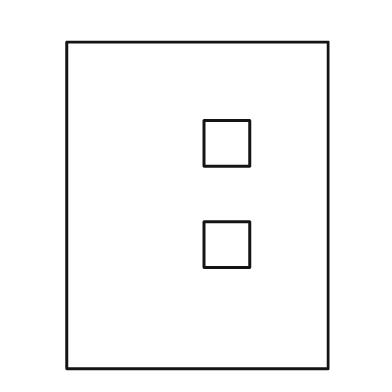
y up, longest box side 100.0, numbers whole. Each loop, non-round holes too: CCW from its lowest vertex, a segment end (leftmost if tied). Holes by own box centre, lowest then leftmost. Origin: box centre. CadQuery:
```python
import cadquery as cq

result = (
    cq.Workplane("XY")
    .moveTo(-40.0, -50.0)
    .lineTo(40.0, -50.0)
    .lineTo(40.0, 50.0)
    .lineTo(-40.0, 50.0)
    .close()
    .moveTo(2.0, -19.0)
    .lineTo(16.0, -19.0)
    .lineTo(16.0, -5.0)
    .lineTo(2.0, -5.0)
    .close()
    .moveTo(2.0, 12.0)
    .lineTo(16.0, 12.0)
    .lineTo(16.0, 26.0)
    .lineTo(2.0, 26.0)
    .close()
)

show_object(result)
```